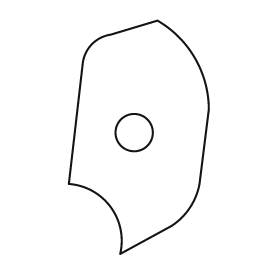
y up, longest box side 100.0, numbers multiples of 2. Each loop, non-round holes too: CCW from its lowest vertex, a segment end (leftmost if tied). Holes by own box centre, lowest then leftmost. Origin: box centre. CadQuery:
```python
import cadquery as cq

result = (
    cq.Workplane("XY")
    .moveTo(-8.0, -50.0)
    .lineTo(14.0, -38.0)
    .threePointArc((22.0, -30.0), (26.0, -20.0))
    .lineTo(30.0, 12.0)
    .threePointArc((24.0, 34.0), (8.0, 50.0))
    .lineTo(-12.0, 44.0)
    .threePointArc((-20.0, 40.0), (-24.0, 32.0))
    .lineTo(-30.0, -20.0)
    .threePointArc((-12.0, -30.0), (-8.0, -50.0))
    .close()
    .moveTo(-2.0, 2.0)
    .circle(8.0)
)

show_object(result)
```